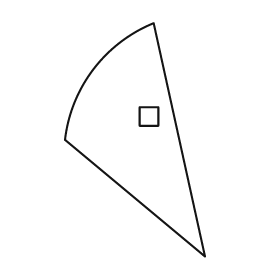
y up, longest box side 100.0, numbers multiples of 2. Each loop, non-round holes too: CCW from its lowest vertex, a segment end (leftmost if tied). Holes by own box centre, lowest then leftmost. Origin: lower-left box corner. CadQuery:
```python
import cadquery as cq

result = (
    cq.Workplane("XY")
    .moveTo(60.0, 0.0)
    .lineTo(38.0, 100.0)
    .threePointArc((12.0, 80.0), (0.0, 50.0))
    .close()
    .moveTo(32.0, 56.0)
    .lineTo(40.0, 56.0)
    .lineTo(40.0, 64.0)
    .lineTo(32.0, 64.0)
    .close()
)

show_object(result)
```